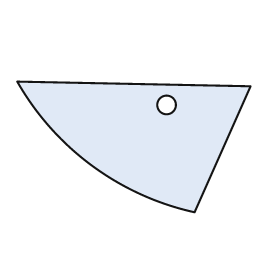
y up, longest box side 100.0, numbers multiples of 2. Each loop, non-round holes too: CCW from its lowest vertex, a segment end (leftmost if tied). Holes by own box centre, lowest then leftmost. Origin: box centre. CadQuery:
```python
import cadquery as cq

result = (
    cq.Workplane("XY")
    .moveTo(26.0, -28.0)
    .lineTo(50.0, 26.0)
    .lineTo(-50.0, 28.0)
    .threePointArc((-18.0, -8.0), (26.0, -28.0))
    .close()
    .moveTo(14.0, 18.0)
    .circle(4.0)
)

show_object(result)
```